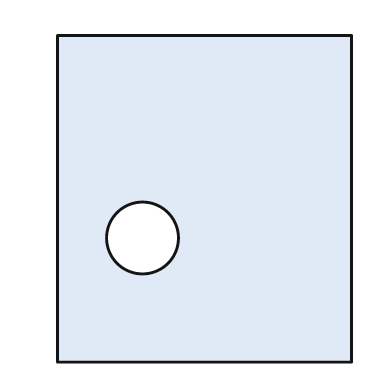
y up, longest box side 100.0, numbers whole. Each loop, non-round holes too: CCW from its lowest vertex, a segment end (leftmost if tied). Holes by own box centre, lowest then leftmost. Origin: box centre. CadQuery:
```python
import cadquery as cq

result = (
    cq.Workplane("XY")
    .moveTo(-45.0, -50.0)
    .lineTo(45.0, -50.0)
    .lineTo(45.0, 50.0)
    .lineTo(-45.0, 50.0)
    .close()
    .moveTo(-19.0, -12.0)
    .circle(11.0)
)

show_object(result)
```